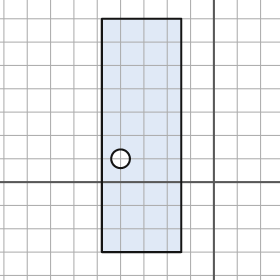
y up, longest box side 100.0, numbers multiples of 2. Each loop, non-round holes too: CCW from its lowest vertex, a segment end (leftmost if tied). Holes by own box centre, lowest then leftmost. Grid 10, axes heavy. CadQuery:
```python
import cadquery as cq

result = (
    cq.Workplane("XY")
    .moveTo(-48.0, -30.0)
    .lineTo(-14.0, -30.0)
    .lineTo(-14.0, 70.0)
    .lineTo(-48.0, 70.0)
    .close()
    .moveTo(-40.0, 10.0)
    .circle(4.0)
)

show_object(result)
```